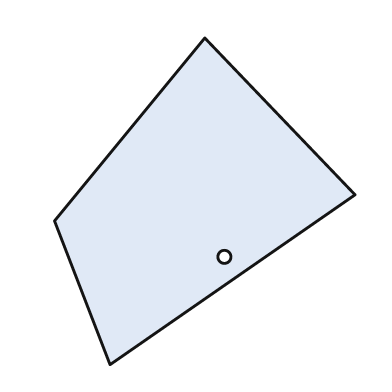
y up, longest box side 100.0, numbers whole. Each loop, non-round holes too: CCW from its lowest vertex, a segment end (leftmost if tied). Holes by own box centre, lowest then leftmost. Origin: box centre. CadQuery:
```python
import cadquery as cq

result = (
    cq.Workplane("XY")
    .moveTo(-29.0, -50.0)
    .lineTo(46.0, 2.0)
    .lineTo(0.0, 50.0)
    .lineTo(-46.0, -6.0)
    .close()
    .moveTo(6.0, -17.0)
    .circle(2.0)
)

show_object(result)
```